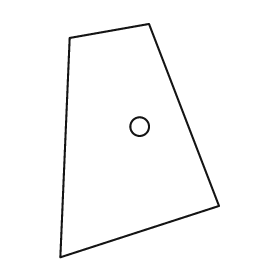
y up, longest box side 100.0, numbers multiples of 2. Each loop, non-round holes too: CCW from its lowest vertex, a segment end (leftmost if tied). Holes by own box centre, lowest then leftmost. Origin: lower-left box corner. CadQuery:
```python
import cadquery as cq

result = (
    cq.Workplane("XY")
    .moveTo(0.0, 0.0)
    .lineTo(68.0, 22.0)
    .lineTo(38.0, 100.0)
    .lineTo(4.0, 94.0)
    .close()
    .moveTo(34.0, 56.0)
    .circle(4.0)
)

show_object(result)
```